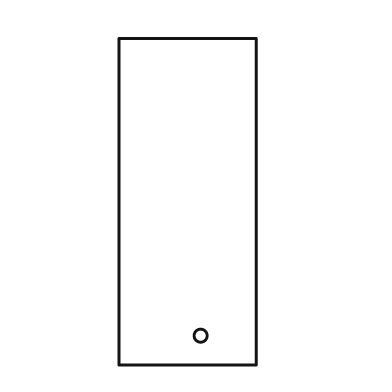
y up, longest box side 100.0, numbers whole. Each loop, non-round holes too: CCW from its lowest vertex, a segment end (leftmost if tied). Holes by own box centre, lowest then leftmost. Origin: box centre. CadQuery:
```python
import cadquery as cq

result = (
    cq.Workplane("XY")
    .moveTo(-21.0, -50.0)
    .lineTo(21.0, -50.0)
    .lineTo(21.0, 50.0)
    .lineTo(-21.0, 50.0)
    .close()
    .moveTo(4.0, -41.0)
    .circle(2.0)
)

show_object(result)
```